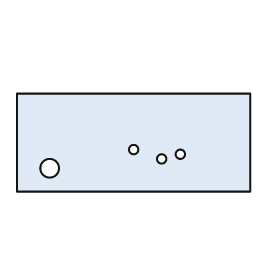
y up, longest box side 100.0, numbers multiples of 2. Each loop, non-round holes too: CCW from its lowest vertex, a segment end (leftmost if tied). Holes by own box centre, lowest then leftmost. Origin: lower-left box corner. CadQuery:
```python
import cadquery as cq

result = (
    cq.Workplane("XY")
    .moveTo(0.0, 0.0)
    .lineTo(100.0, 0.0)
    .lineTo(100.0, 42.0)
    .lineTo(0.0, 42.0)
    .close()
    .moveTo(14.0, 10.0)
    .circle(4.0)
    .moveTo(62.0, 14.0)
    .circle(2.0)
    .moveTo(70.0, 16.0)
    .circle(2.0)
    .moveTo(50.0, 18.0)
    .circle(2.0)
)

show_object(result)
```